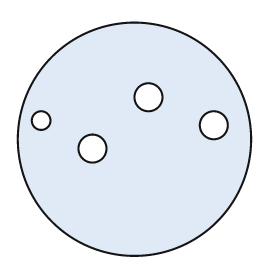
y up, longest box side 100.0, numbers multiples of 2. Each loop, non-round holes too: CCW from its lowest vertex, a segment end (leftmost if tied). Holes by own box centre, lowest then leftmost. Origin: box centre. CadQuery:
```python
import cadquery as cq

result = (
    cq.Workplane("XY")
    .moveTo(0.0, 0.0)
    .circle(50.0)
    .moveTo(-18.0, -4.0)
    .circle(6.0)
    .moveTo(34.0, 6.0)
    .circle(6.0)
    .moveTo(-40.0, 8.0)
    .circle(4.0)
    .moveTo(6.0, 18.0)
    .circle(6.0)
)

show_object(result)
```